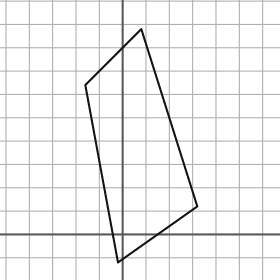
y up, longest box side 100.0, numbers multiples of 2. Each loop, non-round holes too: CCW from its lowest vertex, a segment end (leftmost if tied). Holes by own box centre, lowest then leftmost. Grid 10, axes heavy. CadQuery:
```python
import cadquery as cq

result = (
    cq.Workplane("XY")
    .moveTo(-2.0, -12.0)
    .lineTo(32.0, 12.0)
    .lineTo(8.0, 88.0)
    .lineTo(-16.0, 64.0)
    .close()
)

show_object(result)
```